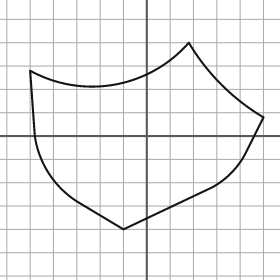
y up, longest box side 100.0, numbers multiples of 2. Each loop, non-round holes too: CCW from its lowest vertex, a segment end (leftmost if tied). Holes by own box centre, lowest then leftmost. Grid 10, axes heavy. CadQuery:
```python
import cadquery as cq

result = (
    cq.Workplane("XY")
    .moveTo(-10.0, -40.0)
    .lineTo(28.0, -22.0)
    .threePointArc((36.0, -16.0), (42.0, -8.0))
    .lineTo(50.0, 8.0)
    .threePointArc((32.0, 22.0), (18.0, 40.0))
    .threePointArc((-14.0, 22.0), (-50.0, 28.0))
    .lineTo(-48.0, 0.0)
    .threePointArc((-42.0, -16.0), (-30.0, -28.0))
    .close()
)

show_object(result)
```